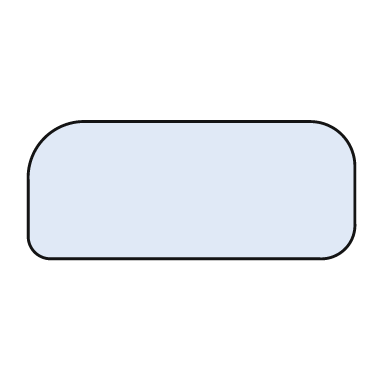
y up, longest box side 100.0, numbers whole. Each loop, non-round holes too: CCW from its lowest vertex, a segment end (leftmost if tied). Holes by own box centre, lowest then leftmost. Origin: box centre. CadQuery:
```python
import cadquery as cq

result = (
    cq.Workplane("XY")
    .moveTo(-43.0, -21.0)
    .lineTo(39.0, -21.0)
    .threePointArc((47.0, -18.0), (50.0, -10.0))
    .lineTo(50.0, 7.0)
    .threePointArc((46.0, 17.0), (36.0, 21.0))
    .lineTo(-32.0, 21.0)
    .threePointArc((-45.0, 16.0), (-50.0, 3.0))
    .lineTo(-50.0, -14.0)
    .threePointArc((-48.0, -19.0), (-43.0, -21.0))
    .close()
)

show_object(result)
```